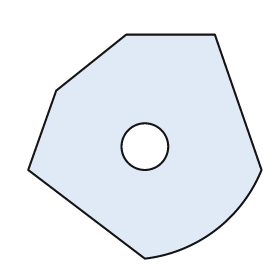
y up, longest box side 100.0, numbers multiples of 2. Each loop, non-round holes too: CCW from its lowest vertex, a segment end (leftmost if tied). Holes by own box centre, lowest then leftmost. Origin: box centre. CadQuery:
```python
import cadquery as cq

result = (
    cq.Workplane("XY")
    .moveTo(0.0, -48.0)
    .threePointArc((30.0, -36.0), (50.0, -10.0))
    .lineTo(30.0, 48.0)
    .lineTo(-8.0, 48.0)
    .lineTo(-38.0, 24.0)
    .lineTo(-50.0, -10.0)
    .close()
    .moveTo(0.0, 0.0)
    .circle(10.0)
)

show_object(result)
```